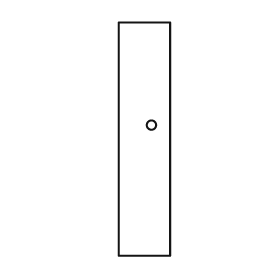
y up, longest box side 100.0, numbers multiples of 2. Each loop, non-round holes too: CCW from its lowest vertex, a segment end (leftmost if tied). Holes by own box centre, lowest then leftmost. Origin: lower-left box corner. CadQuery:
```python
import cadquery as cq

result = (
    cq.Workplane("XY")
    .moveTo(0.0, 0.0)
    .lineTo(22.0, 0.0)
    .lineTo(22.0, 100.0)
    .lineTo(0.0, 100.0)
    .close()
    .moveTo(14.0, 56.0)
    .circle(2.0)
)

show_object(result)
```